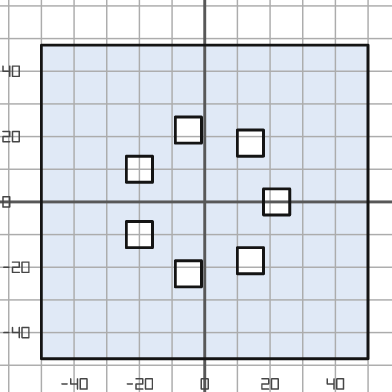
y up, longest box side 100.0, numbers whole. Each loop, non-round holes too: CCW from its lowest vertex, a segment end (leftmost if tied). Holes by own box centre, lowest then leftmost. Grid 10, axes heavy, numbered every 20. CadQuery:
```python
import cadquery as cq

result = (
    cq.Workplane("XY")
    .moveTo(-50.0, -48.0)
    .lineTo(50.0, -48.0)
    .lineTo(50.0, 48.0)
    .lineTo(-50.0, 48.0)
    .close()
    .moveTo(-9.0, -26.0)
    .lineTo(-1.0, -26.0)
    .lineTo(-1.0, -18.0)
    .lineTo(-9.0, -18.0)
    .close()
    .moveTo(10.0, -22.0)
    .lineTo(18.0, -22.0)
    .lineTo(18.0, -14.0)
    .lineTo(10.0, -14.0)
    .close()
    .moveTo(-24.0, -14.0)
    .lineTo(-16.0, -14.0)
    .lineTo(-16.0, -6.0)
    .lineTo(-24.0, -6.0)
    .close()
    .moveTo(18.0, -4.0)
    .lineTo(26.0, -4.0)
    .lineTo(26.0, 4.0)
    .lineTo(18.0, 4.0)
    .close()
    .moveTo(-24.0, 6.0)
    .lineTo(-16.0, 6.0)
    .lineTo(-16.0, 14.0)
    .lineTo(-24.0, 14.0)
    .close()
    .moveTo(10.0, 14.0)
    .lineTo(18.0, 14.0)
    .lineTo(18.0, 22.0)
    .lineTo(10.0, 22.0)
    .close()
    .moveTo(-9.0, 18.0)
    .lineTo(-1.0, 18.0)
    .lineTo(-1.0, 26.0)
    .lineTo(-9.0, 26.0)
    .close()
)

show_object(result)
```